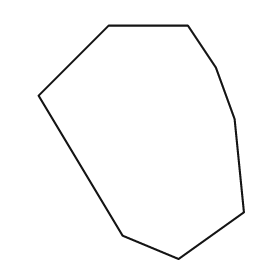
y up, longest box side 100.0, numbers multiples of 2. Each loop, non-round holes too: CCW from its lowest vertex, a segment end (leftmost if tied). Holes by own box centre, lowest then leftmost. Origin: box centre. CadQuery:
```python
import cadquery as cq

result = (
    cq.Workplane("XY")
    .moveTo(16.0, -50.0)
    .lineTo(44.0, -30.0)
    .lineTo(40.0, 10.0)
    .lineTo(32.0, 32.0)
    .lineTo(20.0, 50.0)
    .lineTo(-14.0, 50.0)
    .lineTo(-44.0, 20.0)
    .lineTo(-8.0, -40.0)
    .close()
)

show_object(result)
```